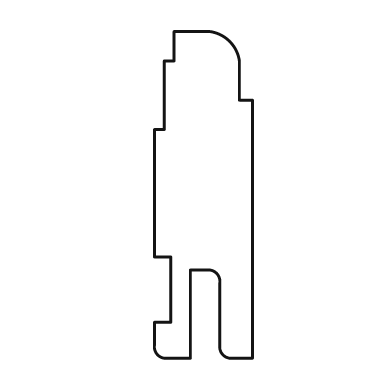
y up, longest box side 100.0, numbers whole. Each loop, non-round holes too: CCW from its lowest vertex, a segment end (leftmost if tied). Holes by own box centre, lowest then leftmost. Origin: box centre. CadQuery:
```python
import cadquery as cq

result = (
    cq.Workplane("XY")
    .moveTo(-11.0, -50.0)
    .lineTo(-4.0, -50.0)
    .lineTo(-4.0, -23.0)
    .lineTo(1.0, -23.0)
    .threePointArc((4.0, -24.0), (5.0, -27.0))
    .lineTo(5.0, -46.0)
    .threePointArc((6.0, -49.0), (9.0, -50.0))
    .lineTo(15.0, -50.0)
    .lineTo(15.0, 29.0)
    .lineTo(11.0, 29.0)
    .lineTo(11.0, 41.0)
    .threePointArc((8.0, 47.0), (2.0, 50.0))
    .lineTo(-9.0, 50.0)
    .lineTo(-9.0, 41.0)
    .lineTo(-12.0, 41.0)
    .lineTo(-12.0, 20.0)
    .lineTo(-15.0, 20.0)
    .lineTo(-15.0, -19.0)
    .lineTo(-10.0, -19.0)
    .lineTo(-10.0, -39.0)
    .lineTo(-15.0, -39.0)
    .lineTo(-15.0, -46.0)
    .threePointArc((-14.0, -49.0), (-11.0, -50.0))
    .close()
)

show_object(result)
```